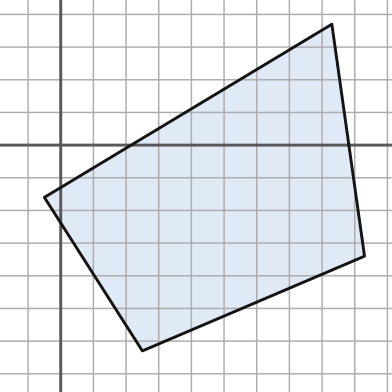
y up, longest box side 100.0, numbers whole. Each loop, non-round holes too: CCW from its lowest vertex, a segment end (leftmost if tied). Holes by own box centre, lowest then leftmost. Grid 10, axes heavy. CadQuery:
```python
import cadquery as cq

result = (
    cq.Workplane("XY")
    .moveTo(25.0, -63.0)
    .lineTo(93.0, -34.0)
    .lineTo(83.0, 37.0)
    .lineTo(-5.0, -16.0)
    .close()
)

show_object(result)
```